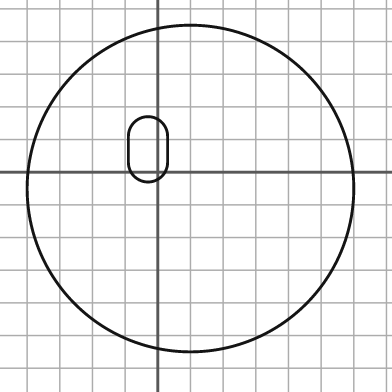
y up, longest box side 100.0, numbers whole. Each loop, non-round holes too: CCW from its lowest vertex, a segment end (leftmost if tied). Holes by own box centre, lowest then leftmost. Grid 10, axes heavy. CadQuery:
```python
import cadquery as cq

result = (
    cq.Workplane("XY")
    .moveTo(10.0, -5.0)
    .circle(50.0)
    .moveTo(-9.0, 3.0)
    .threePointArc((-3.0, -3.0), (3.0, 3.0))
    .lineTo(3.0, 11.0)
    .threePointArc((-3.0, 17.0), (-9.0, 11.0))
    .close()
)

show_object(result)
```